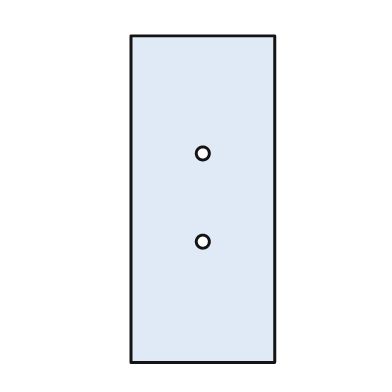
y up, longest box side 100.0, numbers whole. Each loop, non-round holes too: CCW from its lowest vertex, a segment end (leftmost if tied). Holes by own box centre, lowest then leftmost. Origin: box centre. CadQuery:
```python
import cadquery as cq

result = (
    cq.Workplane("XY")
    .moveTo(-22.0, -50.0)
    .lineTo(22.0, -50.0)
    .lineTo(22.0, 50.0)
    .lineTo(-22.0, 50.0)
    .close()
    .moveTo(0.0, -13.0)
    .circle(2.0)
    .moveTo(0.0, 14.0)
    .circle(2.0)
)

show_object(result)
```